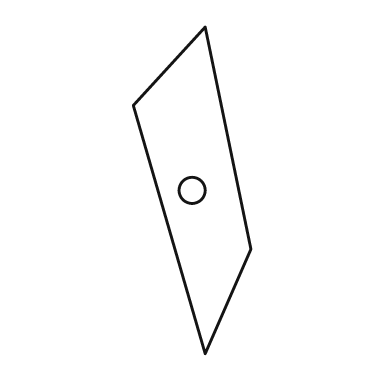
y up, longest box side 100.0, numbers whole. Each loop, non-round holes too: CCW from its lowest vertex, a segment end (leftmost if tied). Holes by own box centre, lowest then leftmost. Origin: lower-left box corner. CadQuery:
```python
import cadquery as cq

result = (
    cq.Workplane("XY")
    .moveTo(22.0, 0.0)
    .lineTo(36.0, 32.0)
    .lineTo(22.0, 100.0)
    .lineTo(0.0, 76.0)
    .close()
    .moveTo(18.0, 50.0)
    .circle(4.0)
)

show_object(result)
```